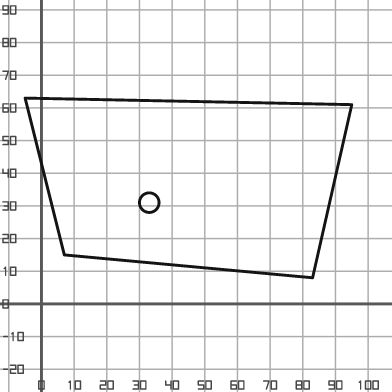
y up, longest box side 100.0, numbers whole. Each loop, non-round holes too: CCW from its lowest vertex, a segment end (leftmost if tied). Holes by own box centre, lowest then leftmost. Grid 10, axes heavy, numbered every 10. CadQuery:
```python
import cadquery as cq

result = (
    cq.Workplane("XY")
    .moveTo(83.0, 8.0)
    .lineTo(95.0, 61.0)
    .lineTo(-5.0, 63.0)
    .lineTo(7.0, 15.0)
    .close()
    .moveTo(33.0, 31.0)
    .circle(3.0)
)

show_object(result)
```